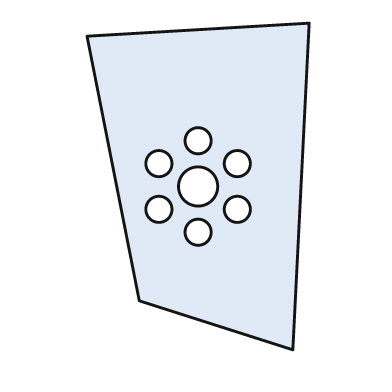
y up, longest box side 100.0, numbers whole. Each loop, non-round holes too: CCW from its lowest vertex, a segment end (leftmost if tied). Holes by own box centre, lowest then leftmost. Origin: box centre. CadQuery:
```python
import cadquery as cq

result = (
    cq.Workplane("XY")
    .moveTo(29.0, -50.0)
    .lineTo(34.0, 50.0)
    .lineTo(-34.0, 46.0)
    .lineTo(-18.0, -35.0)
    .close()
    .moveTo(0.0, -14.0)
    .circle(4.0)
    .moveTo(-12.0, -7.0)
    .circle(4.0)
    .moveTo(12.0, -7.0)
    .circle(4.0)
    .moveTo(0.0, 0.0)
    .circle(6.0)
    .moveTo(-12.0, 7.0)
    .circle(4.0)
    .moveTo(12.0, 7.0)
    .circle(4.0)
    .moveTo(0.0, 14.0)
    .circle(4.0)
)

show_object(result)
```